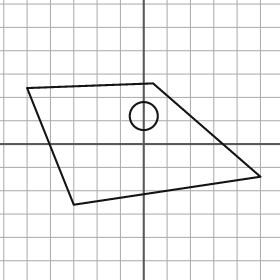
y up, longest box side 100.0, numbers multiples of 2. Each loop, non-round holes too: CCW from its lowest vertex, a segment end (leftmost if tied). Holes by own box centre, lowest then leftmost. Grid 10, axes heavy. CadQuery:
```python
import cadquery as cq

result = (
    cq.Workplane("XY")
    .moveTo(-30.0, -26.0)
    .lineTo(50.0, -14.0)
    .lineTo(4.0, 26.0)
    .lineTo(-50.0, 24.0)
    .close()
    .moveTo(0.0, 12.0)
    .circle(6.0)
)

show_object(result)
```